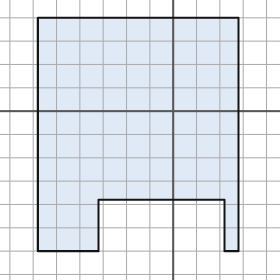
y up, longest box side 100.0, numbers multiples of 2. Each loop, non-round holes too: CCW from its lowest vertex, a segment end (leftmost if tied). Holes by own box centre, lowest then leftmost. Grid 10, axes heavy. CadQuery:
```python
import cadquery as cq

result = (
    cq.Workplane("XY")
    .moveTo(-58.0, -60.0)
    .lineTo(-32.0, -60.0)
    .lineTo(-32.0, -38.0)
    .lineTo(22.0, -38.0)
    .lineTo(22.0, -60.0)
    .lineTo(28.0, -60.0)
    .lineTo(28.0, 40.0)
    .lineTo(-58.0, 40.0)
    .close()
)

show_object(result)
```